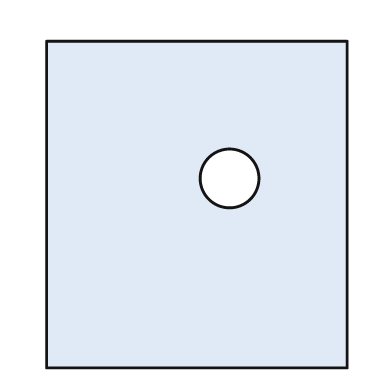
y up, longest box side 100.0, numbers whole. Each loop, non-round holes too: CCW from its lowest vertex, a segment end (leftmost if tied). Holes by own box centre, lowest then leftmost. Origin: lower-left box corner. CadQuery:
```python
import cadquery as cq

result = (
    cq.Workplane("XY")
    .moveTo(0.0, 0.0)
    .lineTo(92.0, 0.0)
    .lineTo(92.0, 100.0)
    .lineTo(0.0, 100.0)
    .close()
    .moveTo(56.0, 58.0)
    .circle(9.0)
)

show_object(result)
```